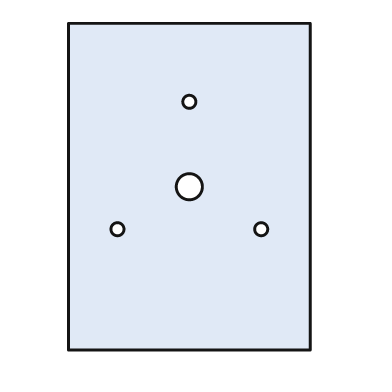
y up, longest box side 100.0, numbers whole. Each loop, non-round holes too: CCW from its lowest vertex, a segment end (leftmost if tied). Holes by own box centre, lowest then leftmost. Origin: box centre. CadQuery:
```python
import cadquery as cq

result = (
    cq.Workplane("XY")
    .moveTo(-37.0, -50.0)
    .lineTo(37.0, -50.0)
    .lineTo(37.0, 50.0)
    .lineTo(-37.0, 50.0)
    .close()
    .moveTo(-22.0, -13.0)
    .circle(2.0)
    .moveTo(22.0, -13.0)
    .circle(2.0)
    .moveTo(0.0, 0.0)
    .circle(4.0)
    .moveTo(0.0, 26.0)
    .circle(2.0)
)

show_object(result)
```